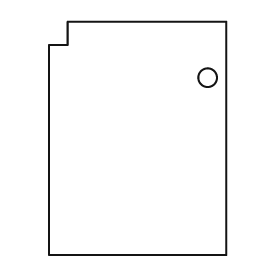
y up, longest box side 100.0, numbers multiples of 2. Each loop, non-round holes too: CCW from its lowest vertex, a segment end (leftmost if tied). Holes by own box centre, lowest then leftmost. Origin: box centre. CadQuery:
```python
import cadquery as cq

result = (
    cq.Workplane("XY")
    .moveTo(-38.0, -50.0)
    .lineTo(38.0, -50.0)
    .lineTo(38.0, 50.0)
    .lineTo(-30.0, 50.0)
    .lineTo(-30.0, 40.0)
    .lineTo(-38.0, 40.0)
    .close()
    .moveTo(30.0, 26.0)
    .circle(4.0)
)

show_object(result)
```